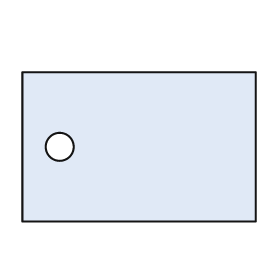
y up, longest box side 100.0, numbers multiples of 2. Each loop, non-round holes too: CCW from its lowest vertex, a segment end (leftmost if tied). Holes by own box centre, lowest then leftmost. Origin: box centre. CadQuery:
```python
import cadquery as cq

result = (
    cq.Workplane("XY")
    .moveTo(-50.0, -32.0)
    .lineTo(50.0, -32.0)
    .lineTo(50.0, 32.0)
    .lineTo(-50.0, 32.0)
    .close()
    .moveTo(-34.0, 0.0)
    .circle(6.0)
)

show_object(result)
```